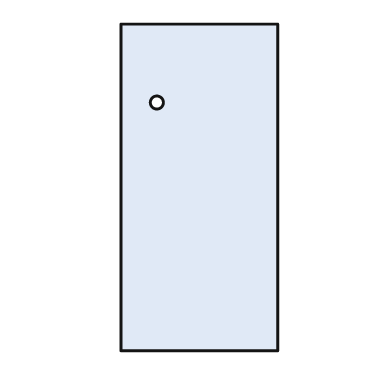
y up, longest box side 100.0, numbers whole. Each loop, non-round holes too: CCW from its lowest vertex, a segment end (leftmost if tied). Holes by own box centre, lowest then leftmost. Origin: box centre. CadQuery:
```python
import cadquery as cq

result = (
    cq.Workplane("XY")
    .moveTo(-24.0, -50.0)
    .lineTo(24.0, -50.0)
    .lineTo(24.0, 50.0)
    .lineTo(-24.0, 50.0)
    .close()
    .moveTo(-13.0, 26.0)
    .circle(2.0)
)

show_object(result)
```